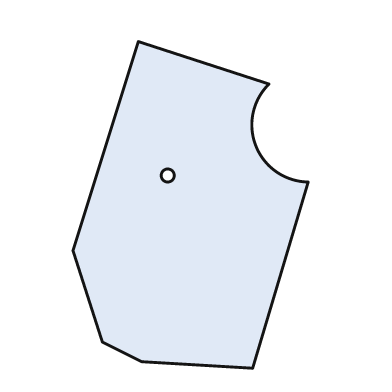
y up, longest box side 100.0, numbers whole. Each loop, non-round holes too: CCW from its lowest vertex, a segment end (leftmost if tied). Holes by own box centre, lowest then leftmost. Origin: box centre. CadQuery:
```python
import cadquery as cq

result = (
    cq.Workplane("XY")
    .moveTo(19.0, -50.0)
    .lineTo(36.0, 7.0)
    .threePointArc((20.0, 18.0), (24.0, 37.0))
    .lineTo(-16.0, 50.0)
    .lineTo(-36.0, -14.0)
    .lineTo(-27.0, -42.0)
    .lineTo(-15.0, -48.0)
    .close()
    .moveTo(-7.0, 9.0)
    .circle(2.0)
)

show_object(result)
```